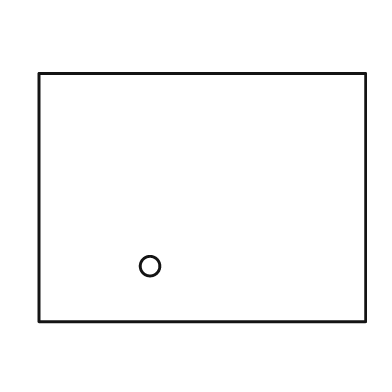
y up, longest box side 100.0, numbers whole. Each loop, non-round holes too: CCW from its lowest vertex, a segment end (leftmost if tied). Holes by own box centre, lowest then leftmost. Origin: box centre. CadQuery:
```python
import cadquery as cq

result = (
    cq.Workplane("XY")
    .moveTo(-50.0, -38.0)
    .lineTo(50.0, -38.0)
    .lineTo(50.0, 38.0)
    .lineTo(-50.0, 38.0)
    .close()
    .moveTo(-16.0, -21.0)
    .circle(3.0)
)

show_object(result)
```